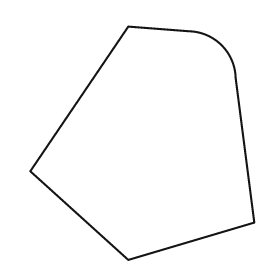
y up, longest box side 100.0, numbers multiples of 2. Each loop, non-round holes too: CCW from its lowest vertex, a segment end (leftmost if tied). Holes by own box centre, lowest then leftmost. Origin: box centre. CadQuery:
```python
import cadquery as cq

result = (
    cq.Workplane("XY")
    .moveTo(-6.0, -50.0)
    .lineTo(48.0, -34.0)
    .lineTo(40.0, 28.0)
    .threePointArc((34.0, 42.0), (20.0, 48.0))
    .lineTo(-6.0, 50.0)
    .lineTo(-48.0, -12.0)
    .close()
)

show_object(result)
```